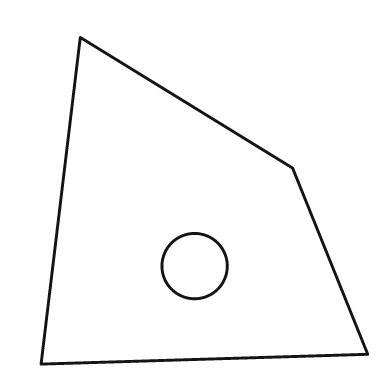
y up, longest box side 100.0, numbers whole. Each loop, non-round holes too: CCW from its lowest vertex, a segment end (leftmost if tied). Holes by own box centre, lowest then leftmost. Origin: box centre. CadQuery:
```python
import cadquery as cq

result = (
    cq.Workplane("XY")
    .moveTo(-50.0, -50.0)
    .lineTo(50.0, -47.0)
    .lineTo(27.0, 10.0)
    .lineTo(-38.0, 50.0)
    .close()
    .moveTo(-3.0, -20.0)
    .circle(10.0)
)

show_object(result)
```